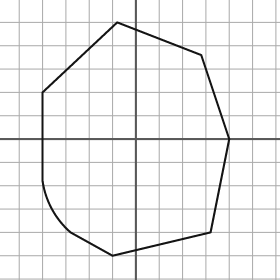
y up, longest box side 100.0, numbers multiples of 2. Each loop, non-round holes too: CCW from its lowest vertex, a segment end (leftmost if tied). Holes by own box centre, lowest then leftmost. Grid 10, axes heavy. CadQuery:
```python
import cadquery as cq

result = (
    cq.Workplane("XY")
    .moveTo(-10.0, -50.0)
    .lineTo(32.0, -40.0)
    .lineTo(40.0, 0.0)
    .lineTo(28.0, 36.0)
    .lineTo(-8.0, 50.0)
    .lineTo(-40.0, 20.0)
    .lineTo(-40.0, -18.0)
    .threePointArc((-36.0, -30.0), (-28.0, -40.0))
    .close()
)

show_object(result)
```